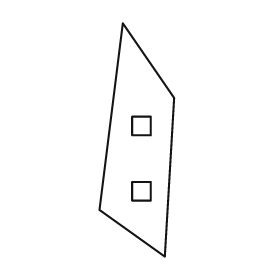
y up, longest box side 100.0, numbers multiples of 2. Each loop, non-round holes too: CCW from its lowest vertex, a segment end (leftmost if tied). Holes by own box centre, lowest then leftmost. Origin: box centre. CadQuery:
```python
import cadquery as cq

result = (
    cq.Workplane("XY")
    .moveTo(12.0, -50.0)
    .lineTo(16.0, 18.0)
    .lineTo(-6.0, 50.0)
    .lineTo(-16.0, -30.0)
    .close()
    .moveTo(-2.0, -26.0)
    .lineTo(6.0, -26.0)
    .lineTo(6.0, -18.0)
    .lineTo(-2.0, -18.0)
    .close()
    .moveTo(-2.0, 2.0)
    .lineTo(6.0, 2.0)
    .lineTo(6.0, 10.0)
    .lineTo(-2.0, 10.0)
    .close()
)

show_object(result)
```